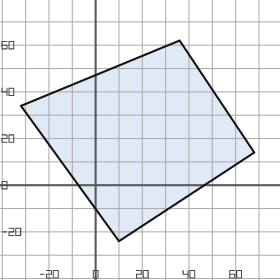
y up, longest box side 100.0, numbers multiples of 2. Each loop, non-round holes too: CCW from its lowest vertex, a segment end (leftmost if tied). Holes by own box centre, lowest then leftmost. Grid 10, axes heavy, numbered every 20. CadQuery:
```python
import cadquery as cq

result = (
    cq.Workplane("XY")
    .moveTo(10.0, -24.0)
    .lineTo(68.0, 14.0)
    .lineTo(36.0, 62.0)
    .lineTo(-32.0, 34.0)
    .close()
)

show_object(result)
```